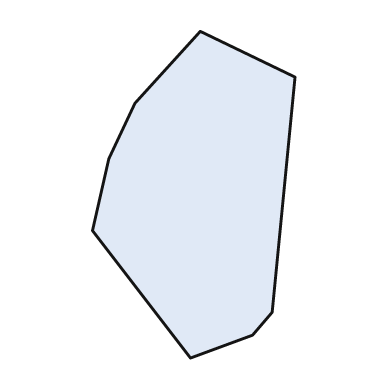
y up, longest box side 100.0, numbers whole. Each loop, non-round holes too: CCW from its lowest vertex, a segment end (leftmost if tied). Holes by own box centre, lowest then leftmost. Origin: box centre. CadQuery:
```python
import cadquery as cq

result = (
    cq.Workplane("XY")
    .moveTo(-1.0, -50.0)
    .lineTo(18.0, -43.0)
    .lineTo(24.0, -36.0)
    .lineTo(31.0, 36.0)
    .lineTo(2.0, 50.0)
    .lineTo(-18.0, 28.0)
    .lineTo(-26.0, 11.0)
    .lineTo(-31.0, -11.0)
    .close()
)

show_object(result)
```